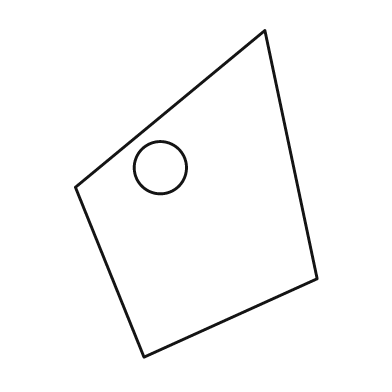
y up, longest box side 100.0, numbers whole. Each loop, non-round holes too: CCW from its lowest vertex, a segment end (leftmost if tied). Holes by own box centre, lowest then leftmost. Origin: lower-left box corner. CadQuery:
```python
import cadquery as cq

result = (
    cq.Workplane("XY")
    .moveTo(21.0, 0.0)
    .lineTo(74.0, 24.0)
    .lineTo(58.0, 100.0)
    .lineTo(0.0, 52.0)
    .close()
    .moveTo(26.0, 58.0)
    .circle(8.0)
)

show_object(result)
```